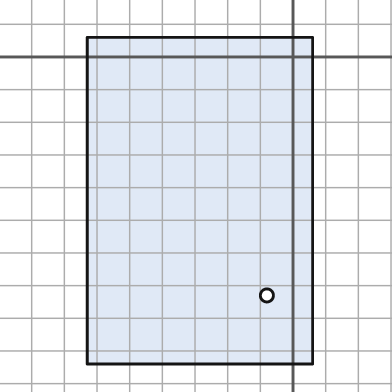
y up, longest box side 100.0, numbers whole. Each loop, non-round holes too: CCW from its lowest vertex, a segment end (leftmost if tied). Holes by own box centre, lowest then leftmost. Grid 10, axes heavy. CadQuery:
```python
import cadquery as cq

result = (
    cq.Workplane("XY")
    .moveTo(-63.0, -94.0)
    .lineTo(6.0, -94.0)
    .lineTo(6.0, 6.0)
    .lineTo(-63.0, 6.0)
    .close()
    .moveTo(-8.0, -73.0)
    .circle(2.0)
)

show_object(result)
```